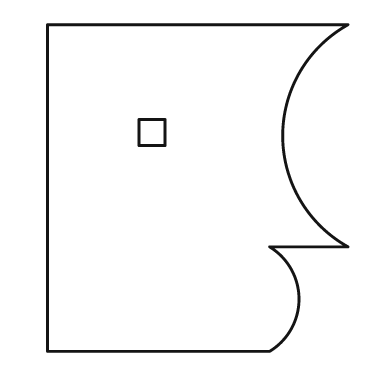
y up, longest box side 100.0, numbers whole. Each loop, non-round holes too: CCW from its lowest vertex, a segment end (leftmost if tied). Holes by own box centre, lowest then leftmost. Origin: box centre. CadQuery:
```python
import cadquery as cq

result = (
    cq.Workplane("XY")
    .moveTo(-46.0, -50.0)
    .lineTo(22.0, -50.0)
    .threePointArc((31.0, -34.0), (22.0, -18.0))
    .lineTo(46.0, -18.0)
    .threePointArc((26.0, 16.0), (46.0, 50.0))
    .lineTo(-46.0, 50.0)
    .close()
    .moveTo(-18.0, 13.0)
    .lineTo(-10.0, 13.0)
    .lineTo(-10.0, 21.0)
    .lineTo(-18.0, 21.0)
    .close()
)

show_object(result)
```